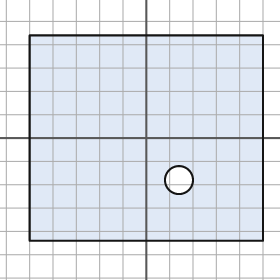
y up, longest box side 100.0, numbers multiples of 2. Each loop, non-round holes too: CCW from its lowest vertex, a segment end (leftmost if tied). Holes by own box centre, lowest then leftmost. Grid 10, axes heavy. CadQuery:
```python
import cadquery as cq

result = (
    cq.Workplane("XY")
    .moveTo(-50.0, -44.0)
    .lineTo(50.0, -44.0)
    .lineTo(50.0, 44.0)
    .lineTo(-50.0, 44.0)
    .close()
    .moveTo(14.0, -18.0)
    .circle(6.0)
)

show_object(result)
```